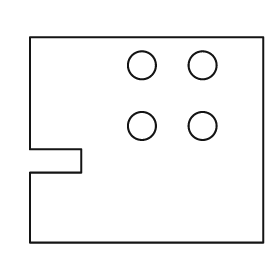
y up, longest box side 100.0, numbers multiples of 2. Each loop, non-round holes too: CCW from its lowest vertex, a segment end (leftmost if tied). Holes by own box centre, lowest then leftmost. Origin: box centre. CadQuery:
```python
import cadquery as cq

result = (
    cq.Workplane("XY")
    .moveTo(-50.0, -44.0)
    .lineTo(50.0, -44.0)
    .lineTo(50.0, 44.0)
    .lineTo(-50.0, 44.0)
    .lineTo(-50.0, -4.0)
    .lineTo(-28.0, -4.0)
    .lineTo(-28.0, -14.0)
    .lineTo(-50.0, -14.0)
    .close()
    .moveTo(-2.0, 6.0)
    .circle(6.0)
    .moveTo(24.0, 6.0)
    .circle(6.0)
    .moveTo(-2.0, 32.0)
    .circle(6.0)
    .moveTo(24.0, 32.0)
    .circle(6.0)
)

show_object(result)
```